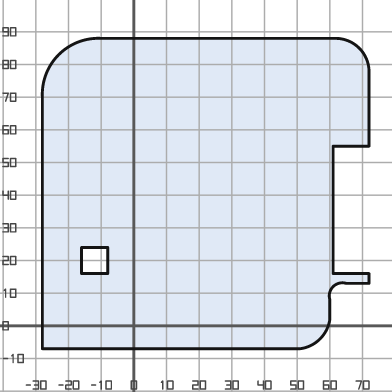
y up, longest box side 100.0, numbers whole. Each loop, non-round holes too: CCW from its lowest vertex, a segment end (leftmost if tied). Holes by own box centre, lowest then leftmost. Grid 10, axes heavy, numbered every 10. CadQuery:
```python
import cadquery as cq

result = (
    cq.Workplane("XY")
    .moveTo(-28.0, -7.0)
    .lineTo(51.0, -7.0)
    .threePointArc((57.0, -4.0), (60.0, 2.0))
    .lineTo(60.0, 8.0)
    .threePointArc((61.0, 12.0), (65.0, 13.0))
    .lineTo(72.0, 13.0)
    .lineTo(72.0, 16.0)
    .lineTo(61.0, 16.0)
    .lineTo(61.0, 55.0)
    .lineTo(72.0, 55.0)
    .lineTo(72.0, 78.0)
    .threePointArc((69.0, 85.0), (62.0, 88.0))
    .lineTo(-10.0, 88.0)
    .threePointArc((-23.0, 83.0), (-28.0, 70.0))
    .close()
    .moveTo(-16.0, 16.0)
    .lineTo(-8.0, 16.0)
    .lineTo(-8.0, 24.0)
    .lineTo(-16.0, 24.0)
    .close()
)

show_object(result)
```